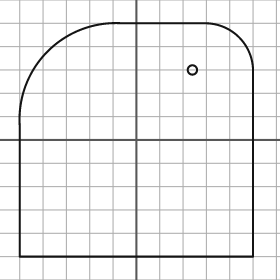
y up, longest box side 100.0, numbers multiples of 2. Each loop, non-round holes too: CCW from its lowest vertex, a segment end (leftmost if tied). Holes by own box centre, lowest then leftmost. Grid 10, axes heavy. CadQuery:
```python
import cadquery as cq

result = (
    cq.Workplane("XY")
    .moveTo(-50.0, -50.0)
    .lineTo(50.0, -50.0)
    .lineTo(50.0, 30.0)
    .threePointArc((44.0, 44.0), (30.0, 50.0))
    .lineTo(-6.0, 50.0)
    .threePointArc((-38.0, 38.0), (-50.0, 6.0))
    .close()
    .moveTo(24.0, 30.0)
    .circle(2.0)
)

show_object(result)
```